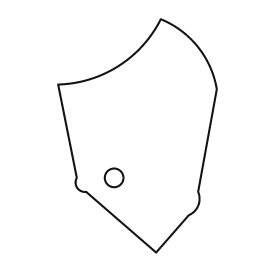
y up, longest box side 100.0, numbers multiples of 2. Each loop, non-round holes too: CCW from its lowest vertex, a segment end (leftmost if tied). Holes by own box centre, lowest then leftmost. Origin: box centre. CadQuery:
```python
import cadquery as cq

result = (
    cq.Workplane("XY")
    .moveTo(8.0, -50.0)
    .lineTo(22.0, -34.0)
    .threePointArc((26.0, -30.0), (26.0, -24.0))
    .lineTo(34.0, 20.0)
    .threePointArc((26.0, 38.0), (10.0, 50.0))
    .threePointArc((-8.0, 30.0), (-34.0, 22.0))
    .lineTo(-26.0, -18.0)
    .threePointArc((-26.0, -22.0), (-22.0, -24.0))
    .close()
    .moveTo(-10.0, -18.0)
    .circle(4.0)
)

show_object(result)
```